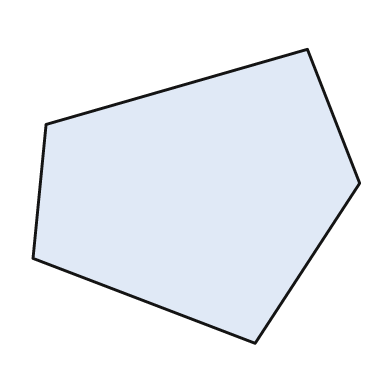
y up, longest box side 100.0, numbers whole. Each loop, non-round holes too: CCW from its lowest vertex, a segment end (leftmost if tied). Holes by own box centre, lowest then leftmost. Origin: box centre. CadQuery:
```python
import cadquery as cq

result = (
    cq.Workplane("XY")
    .moveTo(18.0, -45.0)
    .lineTo(50.0, 4.0)
    .lineTo(34.0, 45.0)
    .lineTo(-46.0, 22.0)
    .lineTo(-50.0, -19.0)
    .close()
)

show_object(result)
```